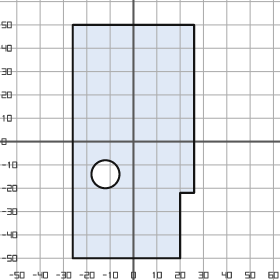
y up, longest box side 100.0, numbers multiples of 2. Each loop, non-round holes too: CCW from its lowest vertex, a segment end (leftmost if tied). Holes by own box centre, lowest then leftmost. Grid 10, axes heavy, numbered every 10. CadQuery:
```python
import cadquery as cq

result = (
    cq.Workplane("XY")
    .moveTo(-26.0, -50.0)
    .lineTo(20.0, -50.0)
    .lineTo(20.0, -22.0)
    .lineTo(26.0, -22.0)
    .lineTo(26.0, 50.0)
    .lineTo(-26.0, 50.0)
    .close()
    .moveTo(-12.0, -14.0)
    .circle(6.0)
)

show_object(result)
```